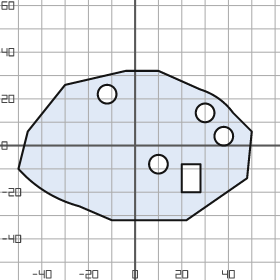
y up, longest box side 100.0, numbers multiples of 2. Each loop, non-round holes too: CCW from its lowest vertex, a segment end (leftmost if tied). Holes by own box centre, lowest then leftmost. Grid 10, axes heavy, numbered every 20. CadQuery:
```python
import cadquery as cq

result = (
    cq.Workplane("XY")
    .moveTo(-10.0, -32.0)
    .lineTo(22.0, -32.0)
    .lineTo(48.0, -14.0)
    .lineTo(50.0, 6.0)
    .lineTo(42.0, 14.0)
    .threePointArc((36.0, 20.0), (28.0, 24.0))
    .lineTo(10.0, 32.0)
    .lineTo(-4.0, 32.0)
    .lineTo(-30.0, 26.0)
    .lineTo(-46.0, 6.0)
    .lineTo(-50.0, -10.0)
    .threePointArc((-38.0, -20.0), (-24.0, -26.0))
    .close()
    .moveTo(20.0, -20.0)
    .lineTo(28.0, -20.0)
    .lineTo(28.0, -8.0)
    .lineTo(20.0, -8.0)
    .close()
    .moveTo(10.0, -8.0)
    .circle(4.0)
    .moveTo(38.0, 4.0)
    .circle(4.0)
    .moveTo(30.0, 14.0)
    .circle(4.0)
    .moveTo(-12.0, 22.0)
    .circle(4.0)
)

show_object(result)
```